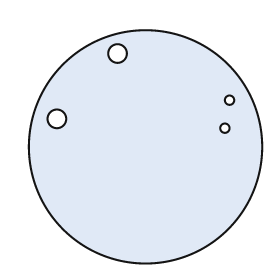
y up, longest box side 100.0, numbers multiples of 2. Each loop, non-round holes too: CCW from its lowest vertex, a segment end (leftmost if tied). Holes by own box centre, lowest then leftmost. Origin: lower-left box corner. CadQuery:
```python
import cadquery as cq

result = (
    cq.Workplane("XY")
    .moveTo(50.0, 50.0)
    .circle(50.0)
    .moveTo(84.0, 58.0)
    .circle(2.0)
    .moveTo(12.0, 62.0)
    .circle(4.0)
    .moveTo(86.0, 70.0)
    .circle(2.0)
    .moveTo(38.0, 90.0)
    .circle(4.0)
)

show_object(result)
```